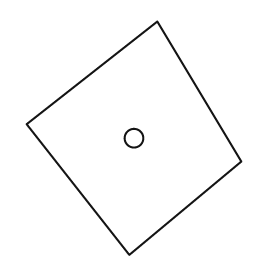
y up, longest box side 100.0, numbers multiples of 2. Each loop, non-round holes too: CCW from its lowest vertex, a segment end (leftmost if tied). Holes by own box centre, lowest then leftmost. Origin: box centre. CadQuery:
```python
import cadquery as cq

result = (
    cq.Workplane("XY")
    .moveTo(-2.0, -50.0)
    .lineTo(46.0, -10.0)
    .lineTo(10.0, 50.0)
    .lineTo(-46.0, 6.0)
    .close()
    .moveTo(0.0, 0.0)
    .circle(4.0)
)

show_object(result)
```